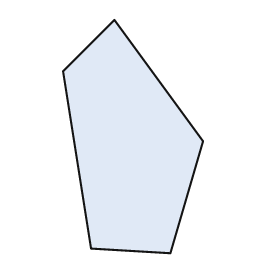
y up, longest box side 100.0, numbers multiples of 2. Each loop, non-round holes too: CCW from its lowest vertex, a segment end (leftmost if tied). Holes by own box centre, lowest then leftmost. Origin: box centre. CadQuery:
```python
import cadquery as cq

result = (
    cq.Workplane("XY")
    .moveTo(16.0, -50.0)
    .lineTo(30.0, -2.0)
    .lineTo(-8.0, 50.0)
    .lineTo(-30.0, 28.0)
    .lineTo(-18.0, -48.0)
    .close()
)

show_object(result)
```